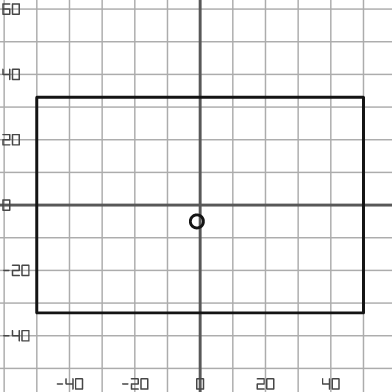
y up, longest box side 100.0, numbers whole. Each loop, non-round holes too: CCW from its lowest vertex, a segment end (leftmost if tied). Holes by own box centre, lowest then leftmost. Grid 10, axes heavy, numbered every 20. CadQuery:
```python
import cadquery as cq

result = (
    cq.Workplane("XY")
    .moveTo(-50.0, -33.0)
    .lineTo(50.0, -33.0)
    .lineTo(50.0, 33.0)
    .lineTo(-50.0, 33.0)
    .close()
    .moveTo(-1.0, -5.0)
    .circle(2.0)
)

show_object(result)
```